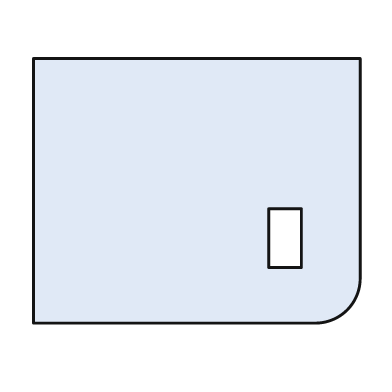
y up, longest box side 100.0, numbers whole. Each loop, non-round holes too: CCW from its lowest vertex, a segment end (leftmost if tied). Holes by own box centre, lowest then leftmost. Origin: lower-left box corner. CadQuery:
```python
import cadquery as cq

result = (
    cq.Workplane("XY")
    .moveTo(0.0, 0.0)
    .lineTo(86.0, 0.0)
    .threePointArc((96.0, 4.0), (100.0, 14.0))
    .lineTo(100.0, 81.0)
    .lineTo(0.0, 81.0)
    .close()
    .moveTo(72.0, 17.0)
    .lineTo(82.0, 17.0)
    .lineTo(82.0, 35.0)
    .lineTo(72.0, 35.0)
    .close()
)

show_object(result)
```